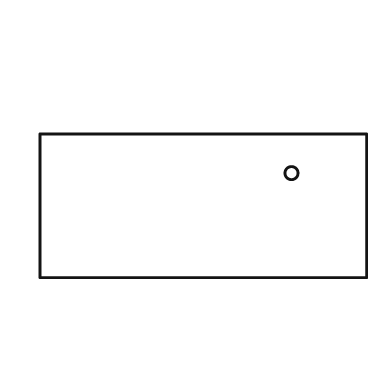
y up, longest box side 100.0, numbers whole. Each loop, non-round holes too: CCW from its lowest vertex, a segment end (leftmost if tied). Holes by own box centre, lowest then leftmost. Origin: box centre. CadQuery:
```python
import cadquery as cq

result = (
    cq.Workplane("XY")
    .moveTo(-50.0, -22.0)
    .lineTo(50.0, -22.0)
    .lineTo(50.0, 22.0)
    .lineTo(-50.0, 22.0)
    .close()
    .moveTo(27.0, 10.0)
    .circle(2.0)
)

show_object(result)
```